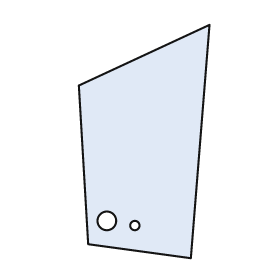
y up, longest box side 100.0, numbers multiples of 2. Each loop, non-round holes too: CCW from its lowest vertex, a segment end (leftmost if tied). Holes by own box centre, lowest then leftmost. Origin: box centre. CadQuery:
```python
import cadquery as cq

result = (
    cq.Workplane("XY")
    .moveTo(20.0, -50.0)
    .lineTo(28.0, 50.0)
    .lineTo(-28.0, 24.0)
    .lineTo(-24.0, -44.0)
    .close()
    .moveTo(-4.0, -36.0)
    .circle(2.0)
    .moveTo(-16.0, -34.0)
    .circle(4.0)
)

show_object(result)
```